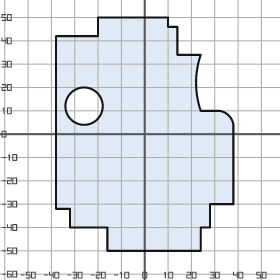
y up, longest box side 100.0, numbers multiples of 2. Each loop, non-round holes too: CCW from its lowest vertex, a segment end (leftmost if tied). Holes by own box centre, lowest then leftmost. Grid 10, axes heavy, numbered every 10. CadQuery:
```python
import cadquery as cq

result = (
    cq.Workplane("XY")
    .moveTo(-16.0, -50.0)
    .lineTo(24.0, -50.0)
    .lineTo(24.0, -40.0)
    .lineTo(28.0, -40.0)
    .lineTo(28.0, -30.0)
    .lineTo(38.0, -30.0)
    .lineTo(38.0, 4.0)
    .threePointArc((36.0, 8.0), (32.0, 10.0))
    .lineTo(24.0, 10.0)
    .threePointArc((22.0, 22.0), (24.0, 34.0))
    .lineTo(14.0, 34.0)
    .lineTo(14.0, 46.0)
    .lineTo(10.0, 46.0)
    .lineTo(10.0, 50.0)
    .lineTo(-20.0, 50.0)
    .lineTo(-20.0, 42.0)
    .lineTo(-38.0, 42.0)
    .lineTo(-38.0, -32.0)
    .lineTo(-32.0, -32.0)
    .lineTo(-32.0, -40.0)
    .lineTo(-16.0, -40.0)
    .close()
    .moveTo(-26.0, 12.0)
    .circle(8.0)
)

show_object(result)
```